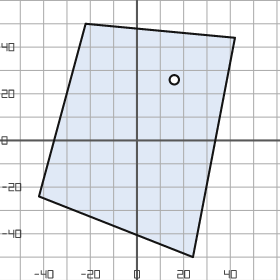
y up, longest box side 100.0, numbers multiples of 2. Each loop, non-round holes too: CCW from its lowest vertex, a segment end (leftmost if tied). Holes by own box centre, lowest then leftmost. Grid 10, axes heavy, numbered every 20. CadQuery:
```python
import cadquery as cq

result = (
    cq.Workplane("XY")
    .moveTo(24.0, -50.0)
    .lineTo(42.0, 44.0)
    .lineTo(-22.0, 50.0)
    .lineTo(-42.0, -24.0)
    .close()
    .moveTo(16.0, 26.0)
    .circle(2.0)
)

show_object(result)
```